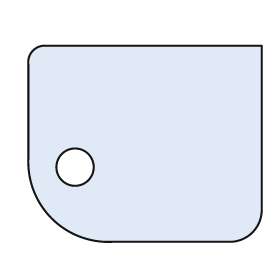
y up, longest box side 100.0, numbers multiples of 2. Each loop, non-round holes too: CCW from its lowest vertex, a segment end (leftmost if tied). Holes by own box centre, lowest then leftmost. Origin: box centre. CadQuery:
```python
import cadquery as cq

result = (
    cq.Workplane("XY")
    .moveTo(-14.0, -42.0)
    .lineTo(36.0, -42.0)
    .threePointArc((46.0, -38.0), (50.0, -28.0))
    .lineTo(50.0, 42.0)
    .lineTo(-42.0, 42.0)
    .threePointArc((-48.0, 40.0), (-50.0, 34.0))
    .lineTo(-50.0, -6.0)
    .threePointArc((-40.0, -32.0), (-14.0, -42.0))
    .close()
    .moveTo(-30.0, -10.0)
    .circle(8.0)
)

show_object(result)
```